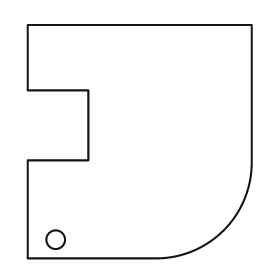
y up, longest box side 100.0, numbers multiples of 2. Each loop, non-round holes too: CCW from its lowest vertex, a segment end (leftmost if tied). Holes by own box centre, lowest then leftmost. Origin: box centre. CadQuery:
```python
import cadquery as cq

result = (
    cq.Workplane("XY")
    .moveTo(-48.0, -50.0)
    .lineTo(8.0, -50.0)
    .threePointArc((36.0, -38.0), (48.0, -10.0))
    .lineTo(48.0, 50.0)
    .lineTo(-48.0, 50.0)
    .lineTo(-48.0, 22.0)
    .lineTo(-22.0, 22.0)
    .lineTo(-22.0, -8.0)
    .lineTo(-48.0, -8.0)
    .close()
    .moveTo(-36.0, -42.0)
    .circle(4.0)
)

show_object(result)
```